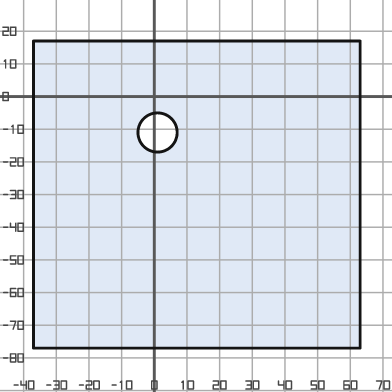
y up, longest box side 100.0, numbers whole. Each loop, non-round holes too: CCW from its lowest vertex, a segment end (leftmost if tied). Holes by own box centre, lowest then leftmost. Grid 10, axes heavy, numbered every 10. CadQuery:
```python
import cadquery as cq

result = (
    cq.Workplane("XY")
    .moveTo(-37.0, -77.0)
    .lineTo(63.0, -77.0)
    .lineTo(63.0, 17.0)
    .lineTo(-37.0, 17.0)
    .close()
    .moveTo(1.0, -11.0)
    .circle(6.0)
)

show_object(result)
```